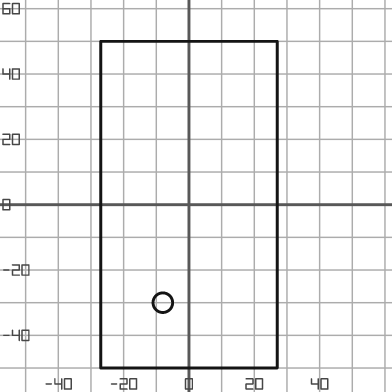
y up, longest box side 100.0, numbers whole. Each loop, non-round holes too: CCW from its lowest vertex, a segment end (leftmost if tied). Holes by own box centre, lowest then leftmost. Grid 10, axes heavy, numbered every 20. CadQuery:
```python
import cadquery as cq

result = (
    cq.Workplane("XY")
    .moveTo(-27.0, -50.0)
    .lineTo(27.0, -50.0)
    .lineTo(27.0, 50.0)
    .lineTo(-27.0, 50.0)
    .close()
    .moveTo(-8.0, -30.0)
    .circle(3.0)
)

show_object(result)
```